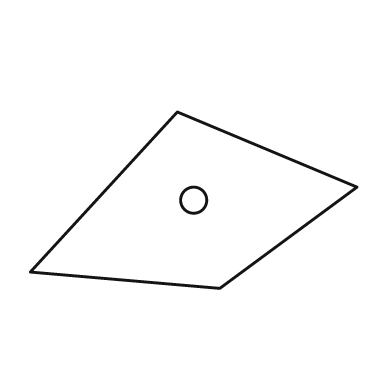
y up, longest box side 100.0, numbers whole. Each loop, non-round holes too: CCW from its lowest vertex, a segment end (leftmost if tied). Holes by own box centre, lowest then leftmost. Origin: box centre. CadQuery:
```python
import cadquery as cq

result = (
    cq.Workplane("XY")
    .moveTo(8.0, -27.0)
    .lineTo(50.0, 4.0)
    .lineTo(-5.0, 27.0)
    .lineTo(-50.0, -22.0)
    .close()
    .moveTo(0.0, 0.0)
    .circle(4.0)
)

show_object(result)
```